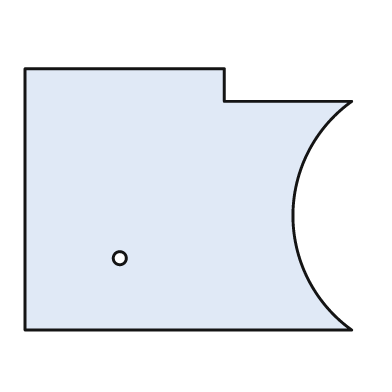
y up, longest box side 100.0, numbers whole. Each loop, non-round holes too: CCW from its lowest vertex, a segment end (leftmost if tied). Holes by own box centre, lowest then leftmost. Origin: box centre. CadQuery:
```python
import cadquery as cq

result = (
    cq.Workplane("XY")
    .moveTo(-50.0, -40.0)
    .lineTo(50.0, -40.0)
    .threePointArc((32.0, -5.0), (50.0, 30.0))
    .lineTo(11.0, 30.0)
    .lineTo(11.0, 40.0)
    .lineTo(-50.0, 40.0)
    .close()
    .moveTo(-21.0, -18.0)
    .circle(2.0)
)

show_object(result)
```